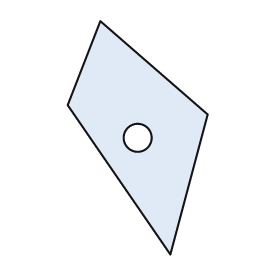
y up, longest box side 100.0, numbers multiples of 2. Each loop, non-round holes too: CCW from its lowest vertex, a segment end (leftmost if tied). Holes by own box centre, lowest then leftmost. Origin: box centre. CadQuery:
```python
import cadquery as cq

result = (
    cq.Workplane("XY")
    .moveTo(14.0, -50.0)
    .lineTo(30.0, 10.0)
    .lineTo(-16.0, 50.0)
    .lineTo(-30.0, 14.0)
    .close()
    .moveTo(0.0, 0.0)
    .circle(6.0)
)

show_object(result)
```